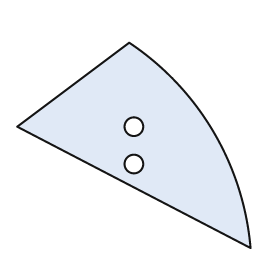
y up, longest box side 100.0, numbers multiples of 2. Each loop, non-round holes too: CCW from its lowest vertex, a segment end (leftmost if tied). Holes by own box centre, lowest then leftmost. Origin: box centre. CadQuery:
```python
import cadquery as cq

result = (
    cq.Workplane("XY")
    .moveTo(50.0, -44.0)
    .threePointArc((34.0, 6.0), (-2.0, 44.0))
    .lineTo(-50.0, 8.0)
    .close()
    .moveTo(0.0, -8.0)
    .circle(4.0)
    .moveTo(0.0, 8.0)
    .circle(4.0)
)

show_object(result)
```